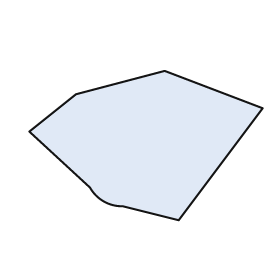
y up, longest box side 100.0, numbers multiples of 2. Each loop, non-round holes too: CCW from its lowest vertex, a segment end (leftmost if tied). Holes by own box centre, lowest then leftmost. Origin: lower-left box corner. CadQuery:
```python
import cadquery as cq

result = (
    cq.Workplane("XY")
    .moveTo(64.0, 0.0)
    .lineTo(100.0, 48.0)
    .lineTo(58.0, 64.0)
    .lineTo(20.0, 54.0)
    .lineTo(0.0, 38.0)
    .lineTo(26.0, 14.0)
    .threePointArc((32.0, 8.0), (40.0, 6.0))
    .close()
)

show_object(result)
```